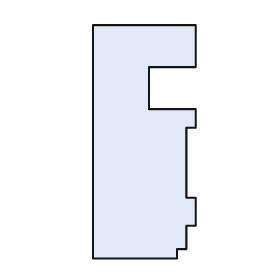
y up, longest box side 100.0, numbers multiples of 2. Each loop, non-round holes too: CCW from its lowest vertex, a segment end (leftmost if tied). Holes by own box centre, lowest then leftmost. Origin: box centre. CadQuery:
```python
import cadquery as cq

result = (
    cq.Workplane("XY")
    .moveTo(-22.0, -50.0)
    .lineTo(14.0, -50.0)
    .lineTo(14.0, -46.0)
    .lineTo(18.0, -46.0)
    .lineTo(18.0, -36.0)
    .lineTo(22.0, -36.0)
    .lineTo(22.0, -24.0)
    .lineTo(18.0, -24.0)
    .lineTo(18.0, 6.0)
    .lineTo(22.0, 6.0)
    .lineTo(22.0, 14.0)
    .lineTo(2.0, 14.0)
    .lineTo(2.0, 32.0)
    .lineTo(22.0, 32.0)
    .lineTo(22.0, 50.0)
    .lineTo(-22.0, 50.0)
    .close()
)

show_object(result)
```